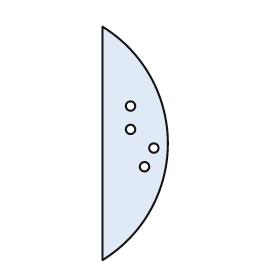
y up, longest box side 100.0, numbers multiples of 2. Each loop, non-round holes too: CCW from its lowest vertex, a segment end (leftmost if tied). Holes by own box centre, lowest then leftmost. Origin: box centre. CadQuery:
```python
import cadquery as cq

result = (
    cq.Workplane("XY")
    .moveTo(-14.0, -50.0)
    .threePointArc((14.0, 0.0), (-14.0, 50.0))
    .close()
    .moveTo(4.0, -10.0)
    .circle(2.0)
    .moveTo(8.0, -2.0)
    .circle(2.0)
    .moveTo(-2.0, 6.0)
    .circle(2.0)
    .moveTo(-2.0, 16.0)
    .circle(2.0)
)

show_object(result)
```